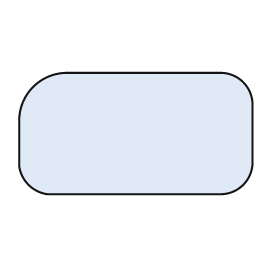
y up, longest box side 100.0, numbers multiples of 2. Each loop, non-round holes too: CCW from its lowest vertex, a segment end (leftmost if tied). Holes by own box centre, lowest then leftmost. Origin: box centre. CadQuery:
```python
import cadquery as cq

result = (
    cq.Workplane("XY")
    .moveTo(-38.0, -26.0)
    .lineTo(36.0, -26.0)
    .threePointArc((46.0, -22.0), (50.0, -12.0))
    .lineTo(50.0, 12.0)
    .threePointArc((46.0, 22.0), (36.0, 26.0))
    .lineTo(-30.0, 26.0)
    .threePointArc((-44.0, 20.0), (-50.0, 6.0))
    .lineTo(-50.0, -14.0)
    .threePointArc((-46.0, -22.0), (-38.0, -26.0))
    .close()
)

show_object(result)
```